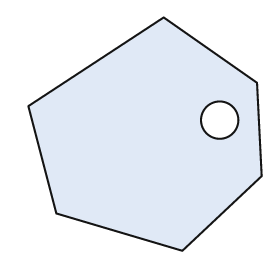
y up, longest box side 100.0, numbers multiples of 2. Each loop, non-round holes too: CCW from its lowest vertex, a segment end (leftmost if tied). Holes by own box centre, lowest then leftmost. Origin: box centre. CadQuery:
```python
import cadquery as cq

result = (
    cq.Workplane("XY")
    .moveTo(16.0, -50.0)
    .lineTo(50.0, -18.0)
    .lineTo(48.0, 22.0)
    .lineTo(8.0, 50.0)
    .lineTo(-50.0, 12.0)
    .lineTo(-38.0, -34.0)
    .close()
    .moveTo(32.0, 6.0)
    .circle(8.0)
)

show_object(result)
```